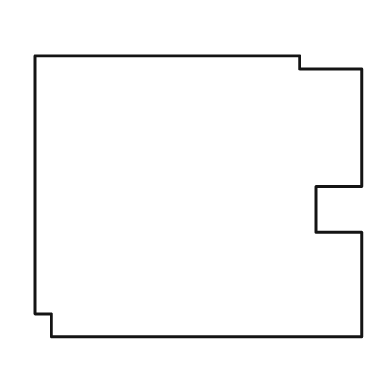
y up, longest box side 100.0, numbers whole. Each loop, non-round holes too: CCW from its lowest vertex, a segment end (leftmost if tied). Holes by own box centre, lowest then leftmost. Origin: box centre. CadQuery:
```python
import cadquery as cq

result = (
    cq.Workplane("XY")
    .moveTo(-45.0, -43.0)
    .lineTo(50.0, -43.0)
    .lineTo(50.0, -11.0)
    .lineTo(36.0, -11.0)
    .lineTo(36.0, 3.0)
    .lineTo(50.0, 3.0)
    .lineTo(50.0, 39.0)
    .lineTo(31.0, 39.0)
    .lineTo(31.0, 43.0)
    .lineTo(-50.0, 43.0)
    .lineTo(-50.0, -36.0)
    .lineTo(-45.0, -36.0)
    .close()
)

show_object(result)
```